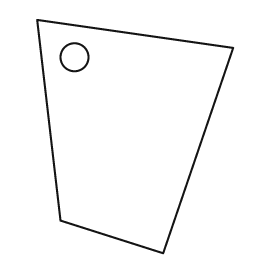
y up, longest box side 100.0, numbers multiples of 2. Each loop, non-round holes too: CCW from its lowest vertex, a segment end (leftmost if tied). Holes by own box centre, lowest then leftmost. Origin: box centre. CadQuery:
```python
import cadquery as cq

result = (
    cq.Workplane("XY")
    .moveTo(12.0, -50.0)
    .lineTo(42.0, 38.0)
    .lineTo(-42.0, 50.0)
    .lineTo(-32.0, -36.0)
    .close()
    .moveTo(-26.0, 34.0)
    .circle(6.0)
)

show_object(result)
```